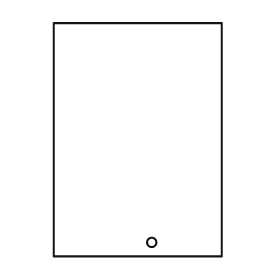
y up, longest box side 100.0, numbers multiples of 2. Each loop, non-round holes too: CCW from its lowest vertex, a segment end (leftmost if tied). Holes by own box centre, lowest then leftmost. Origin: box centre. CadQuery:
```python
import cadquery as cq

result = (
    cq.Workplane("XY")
    .moveTo(-36.0, -50.0)
    .lineTo(36.0, -50.0)
    .lineTo(36.0, 50.0)
    .lineTo(-36.0, 50.0)
    .close()
    .moveTo(6.0, -44.0)
    .circle(2.0)
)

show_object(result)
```